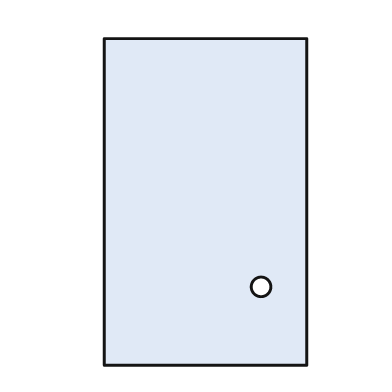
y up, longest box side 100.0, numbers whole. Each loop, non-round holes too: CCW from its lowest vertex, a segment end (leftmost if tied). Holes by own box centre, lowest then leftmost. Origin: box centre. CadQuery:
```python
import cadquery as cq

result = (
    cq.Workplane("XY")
    .moveTo(-31.0, -50.0)
    .lineTo(31.0, -50.0)
    .lineTo(31.0, 50.0)
    .lineTo(-31.0, 50.0)
    .close()
    .moveTo(17.0, -26.0)
    .circle(3.0)
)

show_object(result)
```